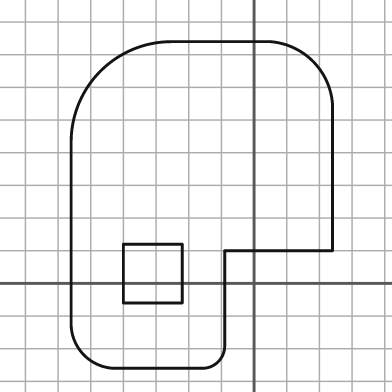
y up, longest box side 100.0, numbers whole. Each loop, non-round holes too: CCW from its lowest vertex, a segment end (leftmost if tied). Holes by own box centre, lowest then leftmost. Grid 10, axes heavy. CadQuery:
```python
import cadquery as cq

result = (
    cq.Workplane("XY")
    .moveTo(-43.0, -26.0)
    .lineTo(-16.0, -26.0)
    .threePointArc((-11.0, -24.0), (-9.0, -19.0))
    .lineTo(-9.0, 10.0)
    .lineTo(24.0, 10.0)
    .lineTo(24.0, 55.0)
    .threePointArc((18.0, 68.0), (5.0, 74.0))
    .lineTo(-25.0, 74.0)
    .threePointArc((-47.0, 65.0), (-56.0, 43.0))
    .lineTo(-56.0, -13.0)
    .threePointArc((-52.0, -22.0), (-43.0, -26.0))
    .close()
    .moveTo(-40.0, -6.0)
    .lineTo(-22.0, -6.0)
    .lineTo(-22.0, 12.0)
    .lineTo(-40.0, 12.0)
    .close()
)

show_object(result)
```